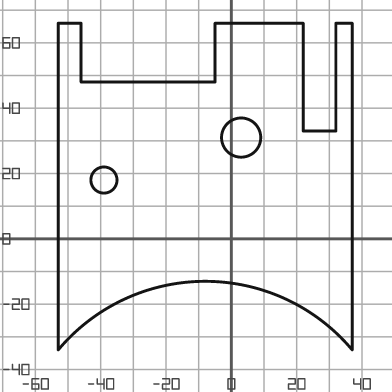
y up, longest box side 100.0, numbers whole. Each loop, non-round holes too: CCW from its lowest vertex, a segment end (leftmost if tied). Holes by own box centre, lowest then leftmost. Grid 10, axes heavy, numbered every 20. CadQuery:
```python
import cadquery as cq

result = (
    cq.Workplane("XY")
    .moveTo(-53.0, -34.0)
    .threePointArc((-8.0, -13.0), (37.0, -34.0))
    .lineTo(37.0, 66.0)
    .lineTo(32.0, 66.0)
    .lineTo(32.0, 33.0)
    .lineTo(22.0, 33.0)
    .lineTo(22.0, 66.0)
    .lineTo(-5.0, 66.0)
    .lineTo(-5.0, 48.0)
    .lineTo(-46.0, 48.0)
    .lineTo(-46.0, 66.0)
    .lineTo(-53.0, 66.0)
    .close()
    .moveTo(-39.0, 18.0)
    .circle(4.0)
    .moveTo(3.0, 31.0)
    .circle(6.0)
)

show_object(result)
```